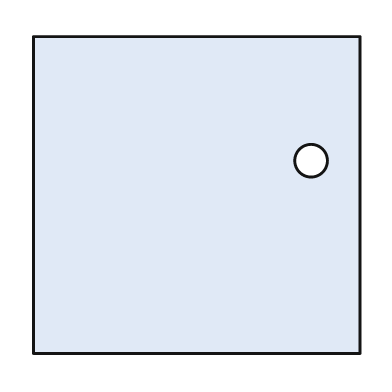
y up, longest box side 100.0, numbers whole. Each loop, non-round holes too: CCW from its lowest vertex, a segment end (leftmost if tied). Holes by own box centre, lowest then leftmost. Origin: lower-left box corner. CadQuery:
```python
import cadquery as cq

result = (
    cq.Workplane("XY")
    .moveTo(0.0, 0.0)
    .lineTo(100.0, 0.0)
    .lineTo(100.0, 97.0)
    .lineTo(0.0, 97.0)
    .close()
    .moveTo(85.0, 59.0)
    .circle(5.0)
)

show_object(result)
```